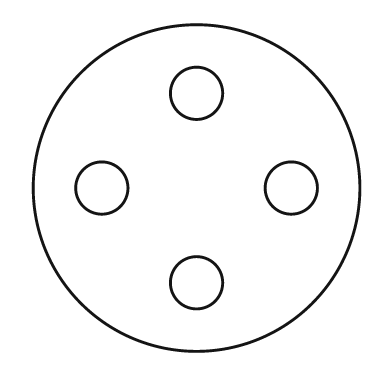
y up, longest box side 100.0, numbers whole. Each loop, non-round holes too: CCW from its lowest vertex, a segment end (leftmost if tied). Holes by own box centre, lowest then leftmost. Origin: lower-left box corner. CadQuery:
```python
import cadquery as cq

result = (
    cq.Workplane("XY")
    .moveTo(50.0, 50.0)
    .circle(50.0)
    .moveTo(50.0, 21.0)
    .circle(8.0)
    .moveTo(21.0, 50.0)
    .circle(8.0)
    .moveTo(79.0, 50.0)
    .circle(8.0)
    .moveTo(50.0, 79.0)
    .circle(8.0)
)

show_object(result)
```